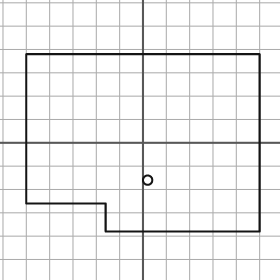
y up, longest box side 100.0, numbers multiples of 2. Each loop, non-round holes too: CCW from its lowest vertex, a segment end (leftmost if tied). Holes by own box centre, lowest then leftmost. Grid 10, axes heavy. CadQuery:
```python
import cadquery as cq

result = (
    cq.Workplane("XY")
    .moveTo(-16.0, -38.0)
    .lineTo(50.0, -38.0)
    .lineTo(50.0, 38.0)
    .lineTo(-50.0, 38.0)
    .lineTo(-50.0, -26.0)
    .lineTo(-16.0, -26.0)
    .close()
    .moveTo(2.0, -16.0)
    .circle(2.0)
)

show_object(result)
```